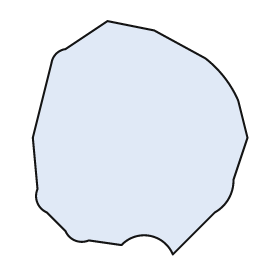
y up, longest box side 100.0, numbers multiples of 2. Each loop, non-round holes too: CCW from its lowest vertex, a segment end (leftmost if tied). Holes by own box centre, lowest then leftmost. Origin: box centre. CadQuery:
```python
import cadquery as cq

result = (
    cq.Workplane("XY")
    .moveTo(14.0, -50.0)
    .lineTo(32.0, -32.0)
    .threePointArc((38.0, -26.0), (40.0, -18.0))
    .lineTo(46.0, 0.0)
    .lineTo(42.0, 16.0)
    .threePointArc((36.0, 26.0), (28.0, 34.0))
    .lineTo(6.0, 46.0)
    .lineTo(-14.0, 50.0)
    .lineTo(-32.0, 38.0)
    .threePointArc((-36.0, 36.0), (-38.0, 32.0))
    .lineTo(-46.0, 0.0)
    .lineTo(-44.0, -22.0)
    .threePointArc((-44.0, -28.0), (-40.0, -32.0))
    .lineTo(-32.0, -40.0)
    .threePointArc((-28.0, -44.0), (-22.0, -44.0))
    .lineTo(-8.0, -46.0)
    .threePointArc((4.0, -42.0), (14.0, -50.0))
    .close()
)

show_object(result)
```